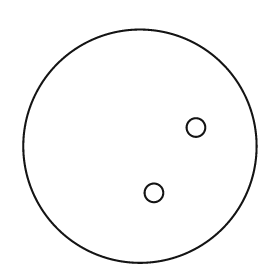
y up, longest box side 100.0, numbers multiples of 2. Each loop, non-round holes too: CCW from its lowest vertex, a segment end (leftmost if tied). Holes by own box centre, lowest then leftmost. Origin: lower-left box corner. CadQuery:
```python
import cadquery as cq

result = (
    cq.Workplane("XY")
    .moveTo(50.0, 50.0)
    .circle(50.0)
    .moveTo(56.0, 30.0)
    .circle(4.0)
    .moveTo(74.0, 58.0)
    .circle(4.0)
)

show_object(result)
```